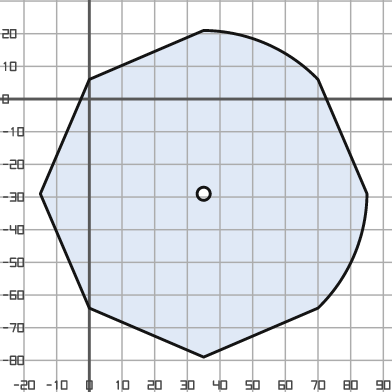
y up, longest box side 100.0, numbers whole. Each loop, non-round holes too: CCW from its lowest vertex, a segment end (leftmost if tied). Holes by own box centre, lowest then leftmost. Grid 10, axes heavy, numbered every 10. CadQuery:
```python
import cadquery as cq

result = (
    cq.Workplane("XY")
    .moveTo(35.0, -79.0)
    .lineTo(70.0, -64.0)
    .threePointArc((81.0, -48.0), (85.0, -29.0))
    .lineTo(70.0, 6.0)
    .threePointArc((54.0, 17.0), (35.0, 21.0))
    .lineTo(0.0, 6.0)
    .lineTo(-15.0, -29.0)
    .lineTo(0.0, -64.0)
    .close()
    .moveTo(35.0, -29.0)
    .circle(2.0)
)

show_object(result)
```